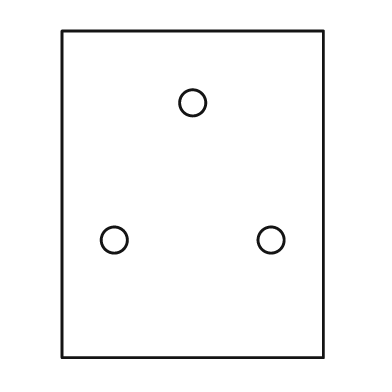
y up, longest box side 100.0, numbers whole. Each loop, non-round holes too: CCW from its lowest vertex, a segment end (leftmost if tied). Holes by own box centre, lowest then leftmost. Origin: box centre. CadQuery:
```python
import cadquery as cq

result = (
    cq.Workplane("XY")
    .moveTo(-40.0, -50.0)
    .lineTo(40.0, -50.0)
    .lineTo(40.0, 50.0)
    .lineTo(-40.0, 50.0)
    .close()
    .moveTo(-24.0, -14.0)
    .circle(4.0)
    .moveTo(24.0, -14.0)
    .circle(4.0)
    .moveTo(0.0, 28.0)
    .circle(4.0)
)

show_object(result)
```